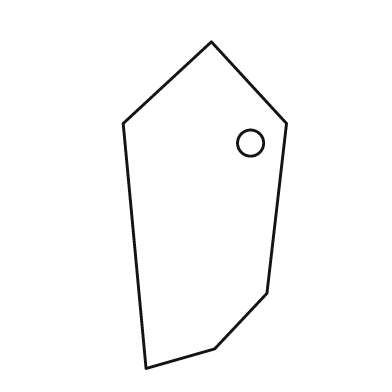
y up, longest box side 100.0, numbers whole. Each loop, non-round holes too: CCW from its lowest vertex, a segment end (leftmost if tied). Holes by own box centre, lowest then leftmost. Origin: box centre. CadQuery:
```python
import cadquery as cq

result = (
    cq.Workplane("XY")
    .moveTo(-18.0, -50.0)
    .lineTo(3.0, -44.0)
    .lineTo(19.0, -27.0)
    .lineTo(25.0, 25.0)
    .lineTo(2.0, 50.0)
    .lineTo(-25.0, 25.0)
    .close()
    .moveTo(14.0, 19.0)
    .circle(4.0)
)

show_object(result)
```